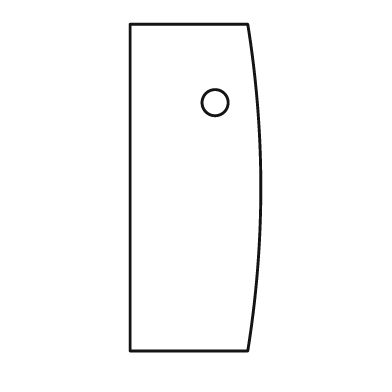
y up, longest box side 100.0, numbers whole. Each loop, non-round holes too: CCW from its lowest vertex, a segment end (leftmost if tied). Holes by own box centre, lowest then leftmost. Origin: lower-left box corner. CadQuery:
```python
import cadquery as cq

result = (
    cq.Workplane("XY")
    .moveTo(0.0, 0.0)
    .lineTo(36.0, 0.0)
    .threePointArc((40.0, 50.0), (36.0, 100.0))
    .lineTo(0.0, 100.0)
    .close()
    .moveTo(26.0, 76.0)
    .circle(4.0)
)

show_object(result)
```